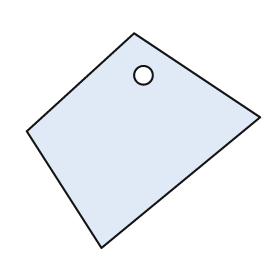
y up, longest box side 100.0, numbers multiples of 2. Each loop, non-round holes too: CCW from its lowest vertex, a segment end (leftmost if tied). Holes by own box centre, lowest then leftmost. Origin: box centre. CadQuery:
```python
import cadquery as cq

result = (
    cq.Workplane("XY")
    .moveTo(-18.0, -46.0)
    .lineTo(50.0, 10.0)
    .lineTo(-4.0, 46.0)
    .lineTo(-50.0, 4.0)
    .close()
    .moveTo(0.0, 28.0)
    .circle(4.0)
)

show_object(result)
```